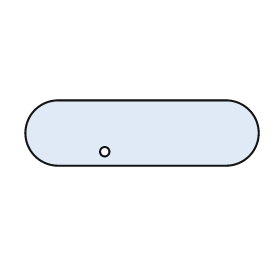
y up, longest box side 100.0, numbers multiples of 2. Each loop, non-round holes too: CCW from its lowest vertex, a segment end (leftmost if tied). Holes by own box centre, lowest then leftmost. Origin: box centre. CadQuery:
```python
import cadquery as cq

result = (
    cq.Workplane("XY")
    .moveTo(-36.0, -14.0)
    .lineTo(36.0, -14.0)
    .threePointArc((50.0, 0.0), (36.0, 14.0))
    .lineTo(-36.0, 14.0)
    .threePointArc((-50.0, 0.0), (-36.0, -14.0))
    .close()
    .moveTo(-16.0, -8.0)
    .circle(2.0)
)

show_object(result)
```